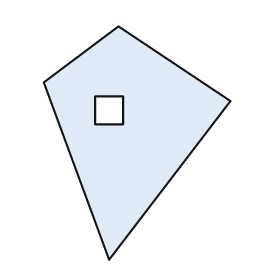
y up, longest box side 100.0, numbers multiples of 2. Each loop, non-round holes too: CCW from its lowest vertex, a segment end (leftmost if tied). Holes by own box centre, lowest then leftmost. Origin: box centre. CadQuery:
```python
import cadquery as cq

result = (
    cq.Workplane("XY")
    .moveTo(-12.0, -50.0)
    .lineTo(40.0, 18.0)
    .lineTo(-8.0, 50.0)
    .lineTo(-40.0, 26.0)
    .close()
    .moveTo(-18.0, 8.0)
    .lineTo(-6.0, 8.0)
    .lineTo(-6.0, 20.0)
    .lineTo(-18.0, 20.0)
    .close()
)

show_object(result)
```